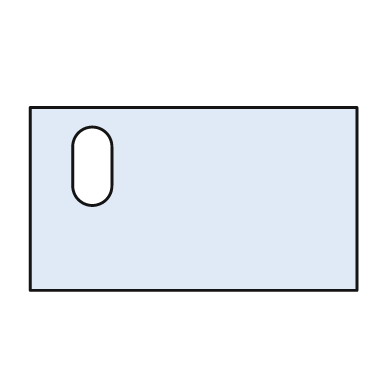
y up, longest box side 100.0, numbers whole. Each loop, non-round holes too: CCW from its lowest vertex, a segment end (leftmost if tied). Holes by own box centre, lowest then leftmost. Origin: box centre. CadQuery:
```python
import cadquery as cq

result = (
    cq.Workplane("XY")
    .moveTo(-50.0, -28.0)
    .lineTo(50.0, -28.0)
    .lineTo(50.0, 28.0)
    .lineTo(-50.0, 28.0)
    .close()
    .moveTo(-37.0, 4.0)
    .threePointArc((-31.0, -2.0), (-25.0, 4.0))
    .lineTo(-25.0, 16.0)
    .threePointArc((-31.0, 22.0), (-37.0, 16.0))
    .close()
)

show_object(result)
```